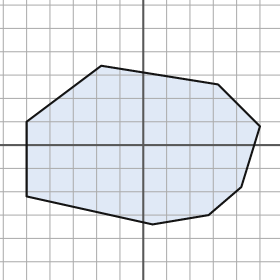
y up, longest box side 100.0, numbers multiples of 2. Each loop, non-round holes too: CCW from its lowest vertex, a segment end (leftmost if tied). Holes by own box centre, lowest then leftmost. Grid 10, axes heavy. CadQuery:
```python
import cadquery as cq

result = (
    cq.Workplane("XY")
    .moveTo(4.0, -34.0)
    .lineTo(28.0, -30.0)
    .lineTo(42.0, -18.0)
    .lineTo(50.0, 8.0)
    .lineTo(32.0, 26.0)
    .lineTo(-18.0, 34.0)
    .lineTo(-50.0, 10.0)
    .lineTo(-50.0, -22.0)
    .close()
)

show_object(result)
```